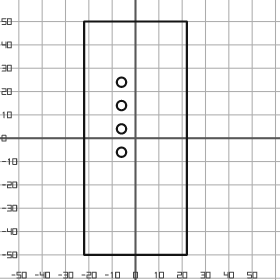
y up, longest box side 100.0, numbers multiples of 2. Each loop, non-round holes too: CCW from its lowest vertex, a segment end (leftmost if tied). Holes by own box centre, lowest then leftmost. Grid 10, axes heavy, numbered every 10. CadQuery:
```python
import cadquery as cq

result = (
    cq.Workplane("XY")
    .moveTo(-22.0, -50.0)
    .lineTo(22.0, -50.0)
    .lineTo(22.0, 50.0)
    .lineTo(-22.0, 50.0)
    .close()
    .moveTo(-6.0, -6.0)
    .circle(2.0)
    .moveTo(-6.0, 4.0)
    .circle(2.0)
    .moveTo(-6.0, 14.0)
    .circle(2.0)
    .moveTo(-6.0, 24.0)
    .circle(2.0)
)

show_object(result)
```